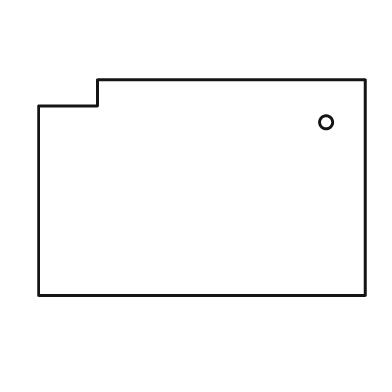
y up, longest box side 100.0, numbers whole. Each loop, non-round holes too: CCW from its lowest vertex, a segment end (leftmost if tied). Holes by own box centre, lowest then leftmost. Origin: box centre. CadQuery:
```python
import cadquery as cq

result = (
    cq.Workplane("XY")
    .moveTo(-50.0, -33.0)
    .lineTo(50.0, -33.0)
    .lineTo(50.0, 33.0)
    .lineTo(-32.0, 33.0)
    .lineTo(-32.0, 25.0)
    .lineTo(-50.0, 25.0)
    .close()
    .moveTo(38.0, 20.0)
    .circle(2.0)
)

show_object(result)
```